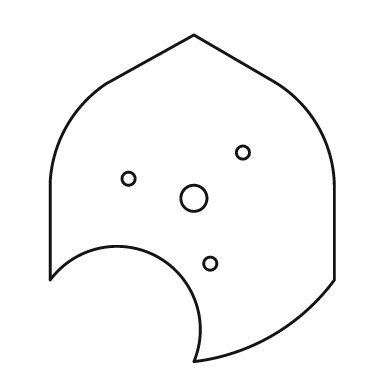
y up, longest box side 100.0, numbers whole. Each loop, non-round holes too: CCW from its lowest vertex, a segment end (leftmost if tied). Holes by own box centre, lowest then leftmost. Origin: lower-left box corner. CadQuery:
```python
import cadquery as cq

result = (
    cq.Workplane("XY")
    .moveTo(44.0, 0.0)
    .threePointArc((68.0, 8.0), (87.0, 25.0))
    .lineTo(87.0, 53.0)
    .threePointArc((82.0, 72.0), (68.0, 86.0))
    .lineTo(44.0, 100.0)
    .lineTo(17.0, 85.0)
    .threePointArc((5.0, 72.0), (0.0, 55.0))
    .lineTo(0.0, 25.0)
    .threePointArc((33.0, 32.0), (44.0, 0.0))
    .close()
    .moveTo(49.0, 30.0)
    .circle(2.0)
    .moveTo(44.0, 50.0)
    .circle(4.0)
    .moveTo(24.0, 56.0)
    .circle(2.0)
    .moveTo(59.0, 64.0)
    .circle(2.0)
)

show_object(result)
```